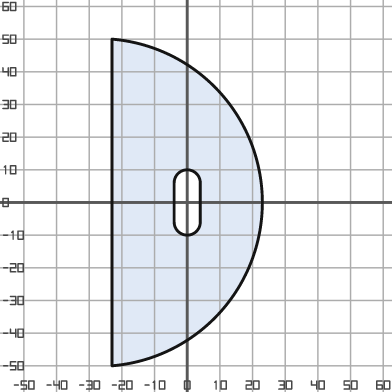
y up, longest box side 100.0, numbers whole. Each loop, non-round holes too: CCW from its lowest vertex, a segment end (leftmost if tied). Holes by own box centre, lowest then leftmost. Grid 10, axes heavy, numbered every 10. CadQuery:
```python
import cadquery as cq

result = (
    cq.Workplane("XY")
    .moveTo(-23.0, -50.0)
    .threePointArc((23.0, 0.0), (-23.0, 50.0))
    .close()
    .moveTo(-4.0, -6.0)
    .threePointArc((0.0, -10.0), (4.0, -6.0))
    .lineTo(4.0, 6.0)
    .threePointArc((0.0, 10.0), (-4.0, 6.0))
    .close()
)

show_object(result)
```